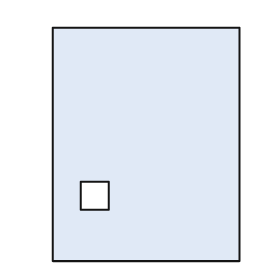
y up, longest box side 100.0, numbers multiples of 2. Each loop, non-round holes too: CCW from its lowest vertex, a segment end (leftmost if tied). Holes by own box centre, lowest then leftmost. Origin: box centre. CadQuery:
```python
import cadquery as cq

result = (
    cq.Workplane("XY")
    .moveTo(-40.0, -50.0)
    .lineTo(40.0, -50.0)
    .lineTo(40.0, 50.0)
    .lineTo(-40.0, 50.0)
    .close()
    .moveTo(-28.0, -28.0)
    .lineTo(-16.0, -28.0)
    .lineTo(-16.0, -16.0)
    .lineTo(-28.0, -16.0)
    .close()
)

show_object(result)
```